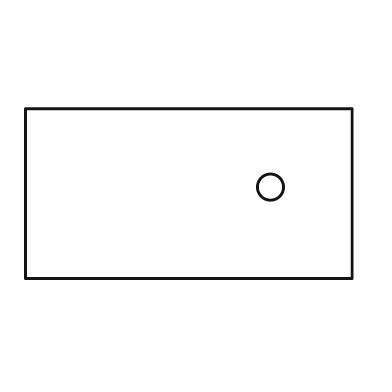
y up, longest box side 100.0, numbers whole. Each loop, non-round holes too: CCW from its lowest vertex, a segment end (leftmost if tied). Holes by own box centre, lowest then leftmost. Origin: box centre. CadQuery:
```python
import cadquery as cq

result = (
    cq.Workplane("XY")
    .moveTo(-50.0, -26.0)
    .lineTo(50.0, -26.0)
    .lineTo(50.0, 26.0)
    .lineTo(-50.0, 26.0)
    .close()
    .moveTo(25.0, 2.0)
    .circle(4.0)
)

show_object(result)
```